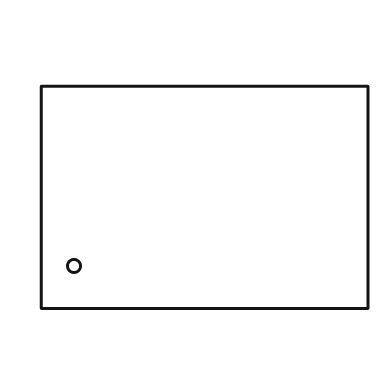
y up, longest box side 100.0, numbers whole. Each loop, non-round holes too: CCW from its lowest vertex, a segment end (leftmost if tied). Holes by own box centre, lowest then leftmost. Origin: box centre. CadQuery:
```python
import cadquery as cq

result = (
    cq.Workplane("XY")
    .moveTo(-50.0, -34.0)
    .lineTo(50.0, -34.0)
    .lineTo(50.0, 34.0)
    .lineTo(-50.0, 34.0)
    .close()
    .moveTo(-40.0, -21.0)
    .circle(2.0)
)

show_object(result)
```